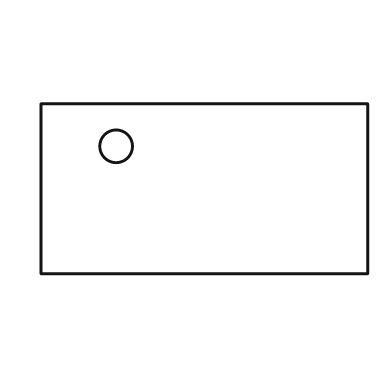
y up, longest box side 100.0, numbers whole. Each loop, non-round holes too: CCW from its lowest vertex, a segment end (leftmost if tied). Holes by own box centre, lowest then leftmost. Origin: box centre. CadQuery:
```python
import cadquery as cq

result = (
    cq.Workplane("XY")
    .moveTo(-50.0, -26.0)
    .lineTo(50.0, -26.0)
    .lineTo(50.0, 26.0)
    .lineTo(-50.0, 26.0)
    .close()
    .moveTo(-27.0, 13.0)
    .circle(5.0)
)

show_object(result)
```